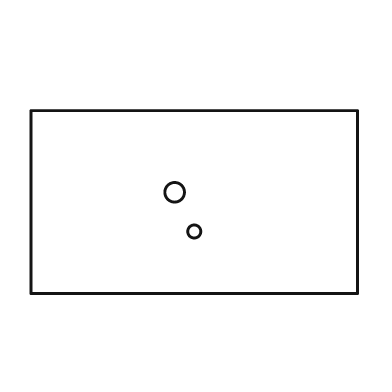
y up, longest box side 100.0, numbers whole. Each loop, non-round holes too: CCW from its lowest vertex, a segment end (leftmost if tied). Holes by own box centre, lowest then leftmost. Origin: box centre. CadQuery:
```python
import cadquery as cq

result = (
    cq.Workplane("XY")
    .moveTo(-50.0, -28.0)
    .lineTo(50.0, -28.0)
    .lineTo(50.0, 28.0)
    .lineTo(-50.0, 28.0)
    .close()
    .moveTo(0.0, -9.0)
    .circle(2.0)
    .moveTo(-6.0, 3.0)
    .circle(3.0)
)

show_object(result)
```